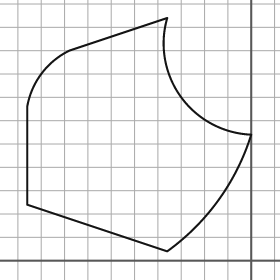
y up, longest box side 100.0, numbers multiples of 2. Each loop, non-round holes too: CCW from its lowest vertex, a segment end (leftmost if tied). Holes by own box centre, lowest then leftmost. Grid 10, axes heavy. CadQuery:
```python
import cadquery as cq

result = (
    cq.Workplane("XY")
    .moveTo(-36.0, 4.0)
    .threePointArc((-14.0, 26.0), (0.0, 54.0))
    .threePointArc((-30.0, 70.0), (-36.0, 104.0))
    .lineTo(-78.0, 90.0)
    .threePointArc((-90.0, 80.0), (-96.0, 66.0))
    .lineTo(-96.0, 24.0)
    .close()
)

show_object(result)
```